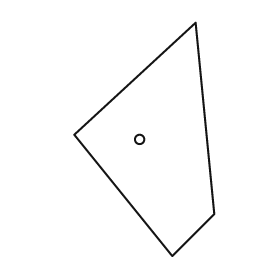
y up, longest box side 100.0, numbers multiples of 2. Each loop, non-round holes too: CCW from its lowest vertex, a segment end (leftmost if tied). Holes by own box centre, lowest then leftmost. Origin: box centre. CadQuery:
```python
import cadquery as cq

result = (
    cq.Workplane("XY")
    .moveTo(12.0, -50.0)
    .lineTo(30.0, -32.0)
    .lineTo(22.0, 50.0)
    .lineTo(-30.0, 2.0)
    .close()
    .moveTo(-2.0, 0.0)
    .circle(2.0)
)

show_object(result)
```